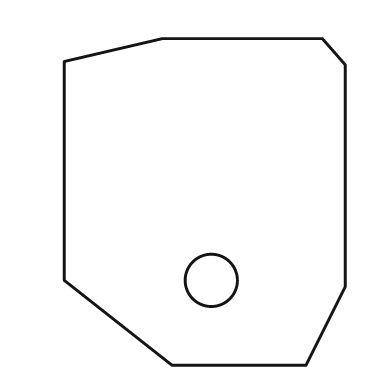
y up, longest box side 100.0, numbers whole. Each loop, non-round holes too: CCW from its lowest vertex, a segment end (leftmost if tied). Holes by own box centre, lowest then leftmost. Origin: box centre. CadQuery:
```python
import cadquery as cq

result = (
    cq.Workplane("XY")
    .moveTo(-10.0, -50.0)
    .lineTo(31.0, -50.0)
    .lineTo(43.0, -26.0)
    .lineTo(43.0, 42.0)
    .lineTo(36.0, 50.0)
    .lineTo(-13.0, 50.0)
    .lineTo(-43.0, 43.0)
    .lineTo(-43.0, -24.0)
    .close()
    .moveTo(2.0, -24.0)
    .circle(8.0)
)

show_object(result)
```